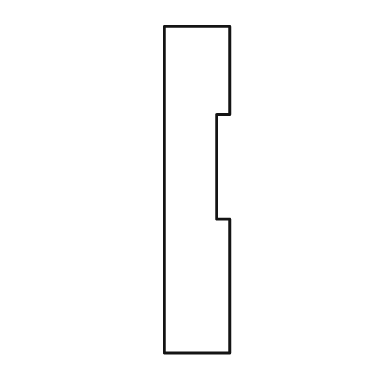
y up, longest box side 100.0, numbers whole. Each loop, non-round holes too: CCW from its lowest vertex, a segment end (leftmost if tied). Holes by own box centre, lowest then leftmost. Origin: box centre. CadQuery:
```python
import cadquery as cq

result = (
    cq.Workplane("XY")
    .moveTo(-10.0, -50.0)
    .lineTo(10.0, -50.0)
    .lineTo(10.0, -9.0)
    .lineTo(6.0, -9.0)
    .lineTo(6.0, 23.0)
    .lineTo(10.0, 23.0)
    .lineTo(10.0, 50.0)
    .lineTo(-10.0, 50.0)
    .close()
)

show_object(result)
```